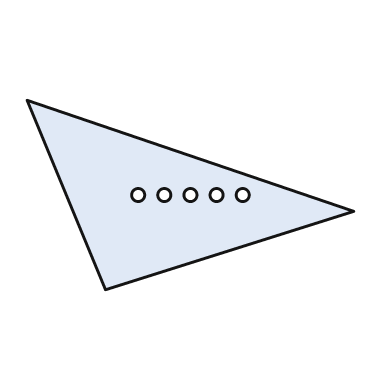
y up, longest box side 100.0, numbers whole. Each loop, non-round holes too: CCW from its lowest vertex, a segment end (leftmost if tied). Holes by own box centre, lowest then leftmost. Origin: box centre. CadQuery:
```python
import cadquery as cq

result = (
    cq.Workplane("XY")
    .moveTo(-26.0, -29.0)
    .lineTo(50.0, -5.0)
    .lineTo(-50.0, 29.0)
    .close()
    .moveTo(-16.0, 0.0)
    .circle(2.0)
    .moveTo(-8.0, 0.0)
    .circle(2.0)
    .moveTo(0.0, 0.0)
    .circle(2.0)
    .moveTo(8.0, 0.0)
    .circle(2.0)
    .moveTo(16.0, 0.0)
    .circle(2.0)
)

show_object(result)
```